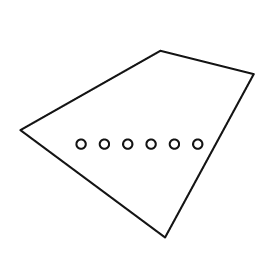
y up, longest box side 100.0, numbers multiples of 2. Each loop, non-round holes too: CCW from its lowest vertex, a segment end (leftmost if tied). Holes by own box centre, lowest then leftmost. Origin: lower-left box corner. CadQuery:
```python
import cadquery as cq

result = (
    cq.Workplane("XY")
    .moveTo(62.0, 0.0)
    .lineTo(100.0, 70.0)
    .lineTo(60.0, 80.0)
    .lineTo(0.0, 46.0)
    .close()
    .moveTo(26.0, 40.0)
    .circle(2.0)
    .moveTo(36.0, 40.0)
    .circle(2.0)
    .moveTo(46.0, 40.0)
    .circle(2.0)
    .moveTo(56.0, 40.0)
    .circle(2.0)
    .moveTo(66.0, 40.0)
    .circle(2.0)
    .moveTo(76.0, 40.0)
    .circle(2.0)
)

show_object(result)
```